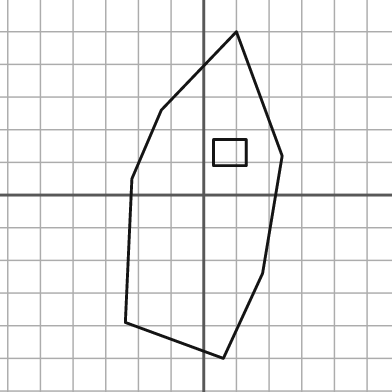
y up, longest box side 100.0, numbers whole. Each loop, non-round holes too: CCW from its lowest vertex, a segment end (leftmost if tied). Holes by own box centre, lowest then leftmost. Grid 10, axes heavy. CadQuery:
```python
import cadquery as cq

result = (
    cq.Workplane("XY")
    .moveTo(6.0, -50.0)
    .lineTo(18.0, -24.0)
    .lineTo(24.0, 12.0)
    .lineTo(10.0, 50.0)
    .lineTo(-13.0, 26.0)
    .lineTo(-22.0, 5.0)
    .lineTo(-24.0, -39.0)
    .close()
    .moveTo(3.0, 9.0)
    .lineTo(13.0, 9.0)
    .lineTo(13.0, 17.0)
    .lineTo(3.0, 17.0)
    .close()
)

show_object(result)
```